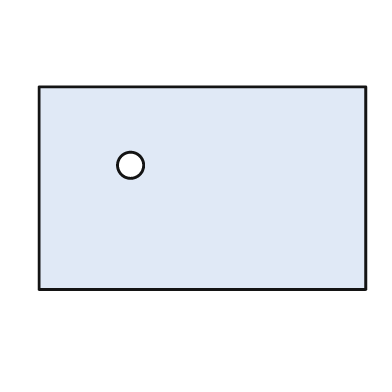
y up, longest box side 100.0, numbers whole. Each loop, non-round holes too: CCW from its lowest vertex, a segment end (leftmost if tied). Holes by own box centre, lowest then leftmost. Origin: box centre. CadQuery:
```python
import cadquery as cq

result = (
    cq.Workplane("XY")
    .moveTo(-50.0, -31.0)
    .lineTo(50.0, -31.0)
    .lineTo(50.0, 31.0)
    .lineTo(-50.0, 31.0)
    .close()
    .moveTo(-22.0, 7.0)
    .circle(4.0)
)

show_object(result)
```